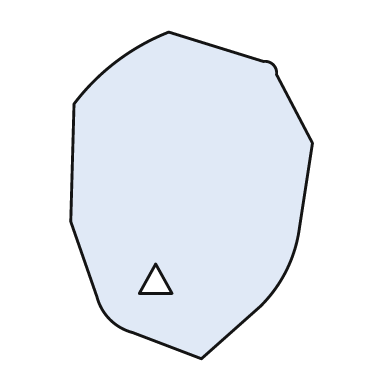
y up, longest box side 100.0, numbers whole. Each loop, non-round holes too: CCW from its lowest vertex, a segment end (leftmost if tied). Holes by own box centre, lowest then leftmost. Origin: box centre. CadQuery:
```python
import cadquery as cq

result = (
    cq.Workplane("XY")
    .moveTo(3.0, -50.0)
    .lineTo(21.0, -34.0)
    .threePointArc((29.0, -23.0), (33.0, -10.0))
    .lineTo(37.0, 16.0)
    .lineTo(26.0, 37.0)
    .threePointArc((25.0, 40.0), (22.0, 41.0))
    .lineTo(-7.0, 50.0)
    .threePointArc((-23.0, 41.0), (-36.0, 28.0))
    .lineTo(-37.0, -8.0)
    .lineTo(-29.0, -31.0)
    .threePointArc((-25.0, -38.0), (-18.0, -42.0))
    .close()
    .moveTo(-16.0, -30.0)
    .lineTo(-6.0, -30.0)
    .lineTo(-11.0, -21.0)
    .close()
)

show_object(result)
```